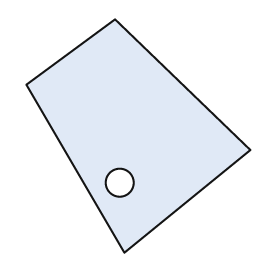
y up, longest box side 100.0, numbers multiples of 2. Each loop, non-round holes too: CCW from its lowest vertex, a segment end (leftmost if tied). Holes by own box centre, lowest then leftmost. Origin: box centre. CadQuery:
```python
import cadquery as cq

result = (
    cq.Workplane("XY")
    .moveTo(-6.0, -50.0)
    .lineTo(48.0, -6.0)
    .lineTo(-10.0, 50.0)
    .lineTo(-48.0, 22.0)
    .close()
    .moveTo(-8.0, -20.0)
    .circle(6.0)
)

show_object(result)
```